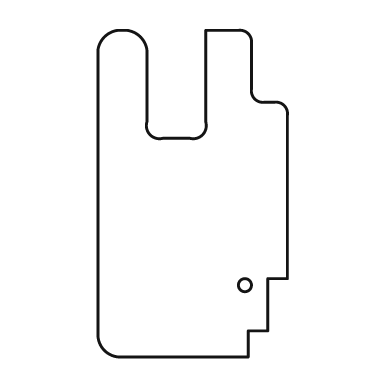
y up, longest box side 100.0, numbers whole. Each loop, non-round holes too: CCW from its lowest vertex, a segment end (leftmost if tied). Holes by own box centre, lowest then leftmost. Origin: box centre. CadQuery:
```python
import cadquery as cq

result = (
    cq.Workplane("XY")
    .moveTo(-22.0, -50.0)
    .lineTo(17.0, -50.0)
    .lineTo(17.0, -42.0)
    .lineTo(23.0, -42.0)
    .lineTo(23.0, -26.0)
    .lineTo(29.0, -26.0)
    .lineTo(29.0, 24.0)
    .threePointArc((28.0, 27.0), (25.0, 28.0))
    .lineTo(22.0, 28.0)
    .threePointArc((19.0, 29.0), (18.0, 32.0))
    .lineTo(18.0, 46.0)
    .threePointArc((17.0, 49.0), (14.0, 50.0))
    .lineTo(4.0, 50.0)
    .lineTo(4.0, 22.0)
    .threePointArc((3.0, 18.0), (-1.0, 17.0))
    .lineTo(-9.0, 17.0)
    .threePointArc((-13.0, 18.0), (-14.0, 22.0))
    .lineTo(-14.0, 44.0)
    .threePointArc((-16.0, 48.0), (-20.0, 50.0))
    .lineTo(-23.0, 50.0)
    .threePointArc((-27.0, 48.0), (-29.0, 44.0))
    .lineTo(-29.0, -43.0)
    .threePointArc((-27.0, -48.0), (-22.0, -50.0))
    .close()
    .moveTo(16.0, -28.0)
    .circle(2.0)
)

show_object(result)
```